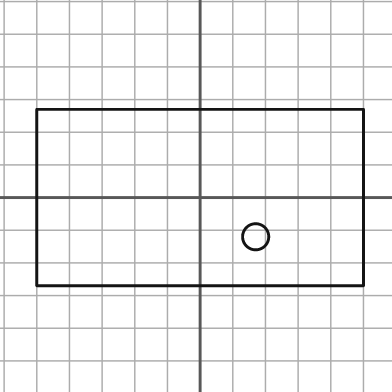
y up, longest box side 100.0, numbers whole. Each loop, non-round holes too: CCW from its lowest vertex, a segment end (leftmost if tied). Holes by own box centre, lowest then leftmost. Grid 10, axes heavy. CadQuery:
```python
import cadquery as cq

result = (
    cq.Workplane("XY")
    .moveTo(-50.0, -27.0)
    .lineTo(50.0, -27.0)
    .lineTo(50.0, 27.0)
    .lineTo(-50.0, 27.0)
    .close()
    .moveTo(17.0, -12.0)
    .circle(4.0)
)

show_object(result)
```